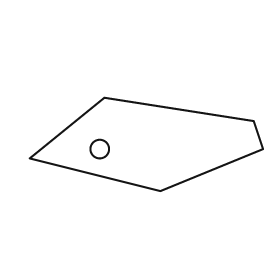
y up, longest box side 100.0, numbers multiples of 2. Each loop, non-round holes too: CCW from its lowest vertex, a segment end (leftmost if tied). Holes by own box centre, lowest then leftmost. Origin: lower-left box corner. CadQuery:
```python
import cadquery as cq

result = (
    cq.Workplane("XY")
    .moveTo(56.0, 0.0)
    .lineTo(100.0, 18.0)
    .lineTo(96.0, 30.0)
    .lineTo(32.0, 40.0)
    .lineTo(0.0, 14.0)
    .close()
    .moveTo(30.0, 18.0)
    .circle(4.0)
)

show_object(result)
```